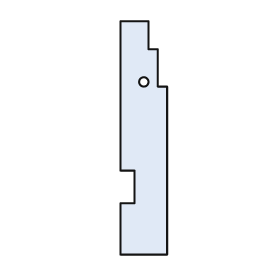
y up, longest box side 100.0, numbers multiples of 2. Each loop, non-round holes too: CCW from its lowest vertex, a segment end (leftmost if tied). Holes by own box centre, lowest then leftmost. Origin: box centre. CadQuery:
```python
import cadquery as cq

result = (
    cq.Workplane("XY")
    .moveTo(-10.0, -50.0)
    .lineTo(10.0, -50.0)
    .lineTo(10.0, 22.0)
    .lineTo(6.0, 22.0)
    .lineTo(6.0, 38.0)
    .lineTo(2.0, 38.0)
    .lineTo(2.0, 50.0)
    .lineTo(-10.0, 50.0)
    .lineTo(-10.0, -14.0)
    .lineTo(-4.0, -14.0)
    .lineTo(-4.0, -28.0)
    .lineTo(-10.0, -28.0)
    .close()
    .moveTo(0.0, 24.0)
    .circle(2.0)
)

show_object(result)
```